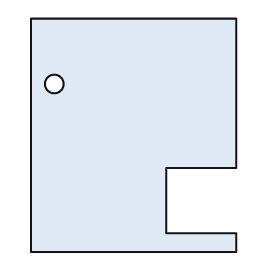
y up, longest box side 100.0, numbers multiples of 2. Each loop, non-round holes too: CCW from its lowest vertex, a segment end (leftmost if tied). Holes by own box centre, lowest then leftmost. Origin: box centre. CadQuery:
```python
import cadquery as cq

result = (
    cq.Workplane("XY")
    .moveTo(-44.0, -50.0)
    .lineTo(44.0, -50.0)
    .lineTo(44.0, -42.0)
    .lineTo(14.0, -42.0)
    .lineTo(14.0, -14.0)
    .lineTo(44.0, -14.0)
    .lineTo(44.0, 50.0)
    .lineTo(-44.0, 50.0)
    .close()
    .moveTo(-34.0, 22.0)
    .circle(4.0)
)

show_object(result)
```